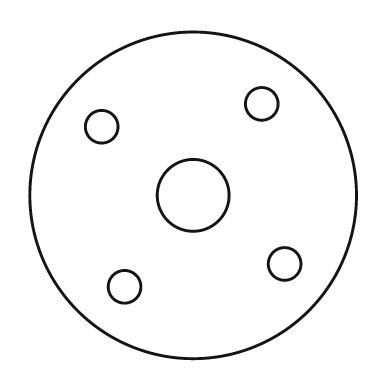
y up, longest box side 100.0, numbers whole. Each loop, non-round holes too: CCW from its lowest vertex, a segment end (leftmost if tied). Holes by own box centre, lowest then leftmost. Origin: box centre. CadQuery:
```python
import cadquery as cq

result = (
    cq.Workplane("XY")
    .moveTo(0.0, 0.0)
    .circle(50.0)
    .moveTo(-21.0, -28.0)
    .circle(5.0)
    .moveTo(28.0, -21.0)
    .circle(5.0)
    .moveTo(0.0, 0.0)
    .circle(11.0)
    .moveTo(-28.0, 21.0)
    .circle(5.0)
    .moveTo(21.0, 28.0)
    .circle(5.0)
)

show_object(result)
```